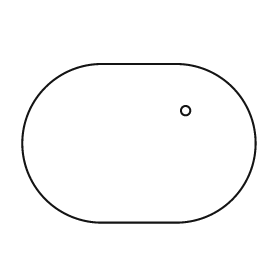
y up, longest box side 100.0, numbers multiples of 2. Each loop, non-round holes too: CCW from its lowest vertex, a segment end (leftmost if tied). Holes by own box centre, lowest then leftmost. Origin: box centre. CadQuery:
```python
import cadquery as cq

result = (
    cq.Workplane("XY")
    .moveTo(-16.0, -34.0)
    .lineTo(16.0, -34.0)
    .threePointArc((50.0, 0.0), (16.0, 34.0))
    .lineTo(-16.0, 34.0)
    .threePointArc((-50.0, 0.0), (-16.0, -34.0))
    .close()
    .moveTo(20.0, 14.0)
    .circle(2.0)
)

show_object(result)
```